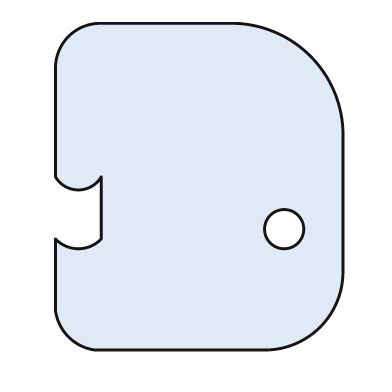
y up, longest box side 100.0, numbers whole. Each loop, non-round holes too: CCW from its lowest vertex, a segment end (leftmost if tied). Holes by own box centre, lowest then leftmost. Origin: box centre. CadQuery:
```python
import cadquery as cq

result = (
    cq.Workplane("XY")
    .moveTo(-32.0, -50.0)
    .lineTo(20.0, -50.0)
    .threePointArc((37.0, -43.0), (44.0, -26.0))
    .lineTo(44.0, 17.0)
    .threePointArc((34.0, 40.0), (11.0, 50.0))
    .lineTo(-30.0, 50.0)
    .threePointArc((-40.0, 46.0), (-44.0, 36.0))
    .lineTo(-44.0, 3.0)
    .threePointArc((-37.0, -1.0), (-30.0, 3.0))
    .lineTo(-30.0, -16.0)
    .threePointArc((-37.0, -19.0), (-44.0, -16.0))
    .lineTo(-44.0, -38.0)
    .threePointArc((-40.0, -46.0), (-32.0, -50.0))
    .close()
    .moveTo(26.0, -13.0)
    .circle(6.0)
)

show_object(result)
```